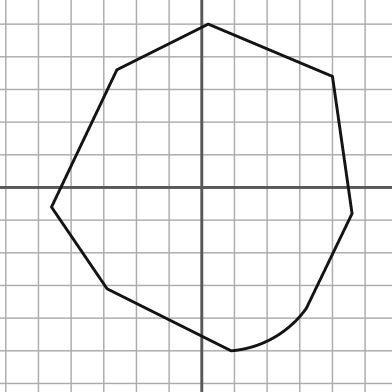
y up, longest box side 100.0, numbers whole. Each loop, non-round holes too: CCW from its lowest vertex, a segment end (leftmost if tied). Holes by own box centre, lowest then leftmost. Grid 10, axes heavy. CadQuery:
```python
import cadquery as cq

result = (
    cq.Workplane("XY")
    .moveTo(9.0, -50.0)
    .threePointArc((22.0, -46.0), (32.0, -37.0))
    .lineTo(46.0, -8.0)
    .lineTo(40.0, 34.0)
    .lineTo(2.0, 50.0)
    .lineTo(-26.0, 36.0)
    .lineTo(-46.0, -6.0)
    .lineTo(-29.0, -31.0)
    .close()
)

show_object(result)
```